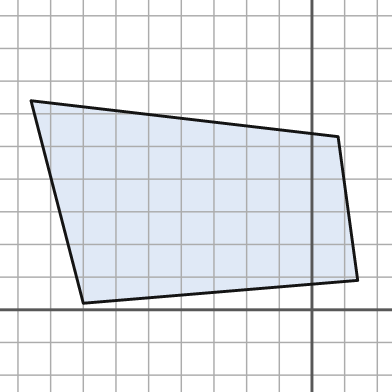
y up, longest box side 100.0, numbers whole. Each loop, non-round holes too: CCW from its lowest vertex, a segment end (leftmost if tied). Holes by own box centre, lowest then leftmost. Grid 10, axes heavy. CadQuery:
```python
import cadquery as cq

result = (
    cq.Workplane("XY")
    .moveTo(-70.0, 2.0)
    .lineTo(14.0, 9.0)
    .lineTo(8.0, 53.0)
    .lineTo(-86.0, 64.0)
    .close()
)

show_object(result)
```